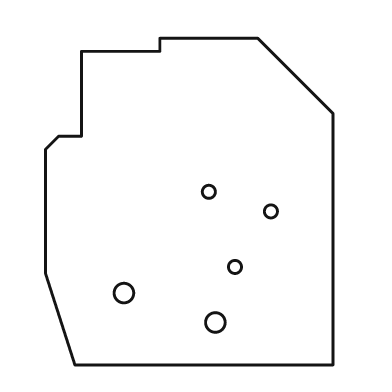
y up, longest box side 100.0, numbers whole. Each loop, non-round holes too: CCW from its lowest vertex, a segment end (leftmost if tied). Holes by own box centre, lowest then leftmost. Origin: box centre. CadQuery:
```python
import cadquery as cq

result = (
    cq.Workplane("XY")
    .moveTo(-35.0, -50.0)
    .lineTo(44.0, -50.0)
    .lineTo(44.0, 27.0)
    .lineTo(21.0, 50.0)
    .lineTo(-9.0, 50.0)
    .lineTo(-9.0, 46.0)
    .lineTo(-33.0, 46.0)
    .lineTo(-33.0, 20.0)
    .lineTo(-40.0, 20.0)
    .lineTo(-44.0, 16.0)
    .lineTo(-44.0, -22.0)
    .close()
    .moveTo(8.0, -37.0)
    .circle(3.0)
    .moveTo(-20.0, -28.0)
    .circle(3.0)
    .moveTo(14.0, -20.0)
    .circle(2.0)
    .moveTo(25.0, -3.0)
    .circle(2.0)
    .moveTo(6.0, 3.0)
    .circle(2.0)
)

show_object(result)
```